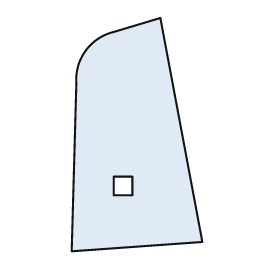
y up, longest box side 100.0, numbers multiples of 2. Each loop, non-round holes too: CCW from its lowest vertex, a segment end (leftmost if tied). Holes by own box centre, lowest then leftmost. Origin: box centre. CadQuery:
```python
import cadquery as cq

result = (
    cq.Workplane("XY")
    .moveTo(-28.0, -50.0)
    .lineTo(28.0, -46.0)
    .lineTo(10.0, 50.0)
    .lineTo(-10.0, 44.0)
    .threePointArc((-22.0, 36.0), (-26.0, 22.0))
    .close()
    .moveTo(-10.0, -26.0)
    .lineTo(-2.0, -26.0)
    .lineTo(-2.0, -18.0)
    .lineTo(-10.0, -18.0)
    .close()
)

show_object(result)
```